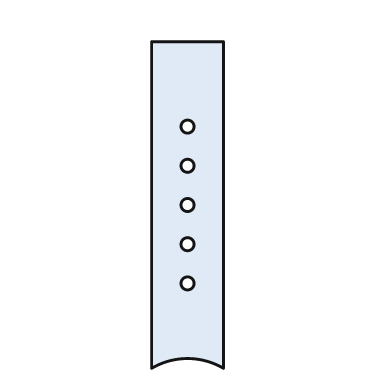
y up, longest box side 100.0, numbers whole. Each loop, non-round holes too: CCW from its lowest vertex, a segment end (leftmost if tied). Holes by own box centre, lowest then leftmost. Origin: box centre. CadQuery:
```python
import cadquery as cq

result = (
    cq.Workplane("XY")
    .moveTo(-11.0, -50.0)
    .threePointArc((0.0, -47.0), (11.0, -50.0))
    .lineTo(11.0, 50.0)
    .lineTo(-11.0, 50.0)
    .close()
    .moveTo(0.0, -24.0)
    .circle(2.0)
    .moveTo(0.0, -12.0)
    .circle(2.0)
    .moveTo(0.0, 0.0)
    .circle(2.0)
    .moveTo(0.0, 12.0)
    .circle(2.0)
    .moveTo(0.0, 24.0)
    .circle(2.0)
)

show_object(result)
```